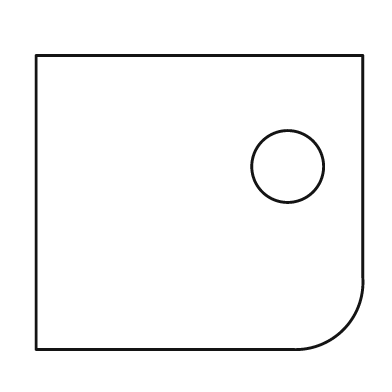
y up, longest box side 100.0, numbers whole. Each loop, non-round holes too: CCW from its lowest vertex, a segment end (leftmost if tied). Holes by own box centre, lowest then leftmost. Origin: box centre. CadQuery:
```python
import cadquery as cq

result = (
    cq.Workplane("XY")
    .moveTo(-50.0, -45.0)
    .lineTo(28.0, -45.0)
    .threePointArc((44.0, -39.0), (50.0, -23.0))
    .lineTo(50.0, 45.0)
    .lineTo(-50.0, 45.0)
    .close()
    .moveTo(27.0, 11.0)
    .circle(11.0)
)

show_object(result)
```